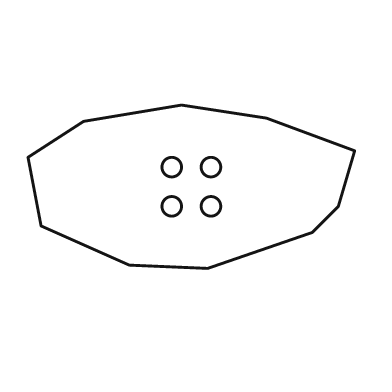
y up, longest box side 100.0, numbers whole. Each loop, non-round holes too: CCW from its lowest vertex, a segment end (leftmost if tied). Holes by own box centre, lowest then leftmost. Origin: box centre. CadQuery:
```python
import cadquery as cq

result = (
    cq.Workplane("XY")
    .moveTo(5.0, -25.0)
    .lineTo(37.0, -14.0)
    .lineTo(45.0, -6.0)
    .lineTo(50.0, 11.0)
    .lineTo(23.0, 21.0)
    .lineTo(-3.0, 25.0)
    .lineTo(-33.0, 20.0)
    .lineTo(-50.0, 9.0)
    .lineTo(-46.0, -12.0)
    .lineTo(-19.0, -24.0)
    .close()
    .moveTo(-6.0, -6.0)
    .circle(3.0)
    .moveTo(6.0, -6.0)
    .circle(3.0)
    .moveTo(-6.0, 6.0)
    .circle(3.0)
    .moveTo(6.0, 6.0)
    .circle(3.0)
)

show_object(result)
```